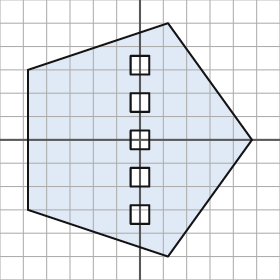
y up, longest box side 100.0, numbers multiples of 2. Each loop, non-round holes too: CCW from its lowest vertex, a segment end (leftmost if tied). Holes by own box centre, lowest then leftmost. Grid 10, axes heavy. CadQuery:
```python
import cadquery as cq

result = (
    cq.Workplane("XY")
    .moveTo(12.0, -50.0)
    .lineTo(48.0, 0.0)
    .lineTo(12.0, 50.0)
    .lineTo(-48.0, 30.0)
    .lineTo(-48.0, -30.0)
    .close()
    .moveTo(-4.0, -36.0)
    .lineTo(4.0, -36.0)
    .lineTo(4.0, -28.0)
    .lineTo(-4.0, -28.0)
    .close()
    .moveTo(-4.0, -20.0)
    .lineTo(4.0, -20.0)
    .lineTo(4.0, -12.0)
    .lineTo(-4.0, -12.0)
    .close()
    .moveTo(-4.0, -4.0)
    .lineTo(4.0, -4.0)
    .lineTo(4.0, 4.0)
    .lineTo(-4.0, 4.0)
    .close()
    .moveTo(-4.0, 12.0)
    .lineTo(4.0, 12.0)
    .lineTo(4.0, 20.0)
    .lineTo(-4.0, 20.0)
    .close()
    .moveTo(-4.0, 28.0)
    .lineTo(4.0, 28.0)
    .lineTo(4.0, 36.0)
    .lineTo(-4.0, 36.0)
    .close()
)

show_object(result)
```